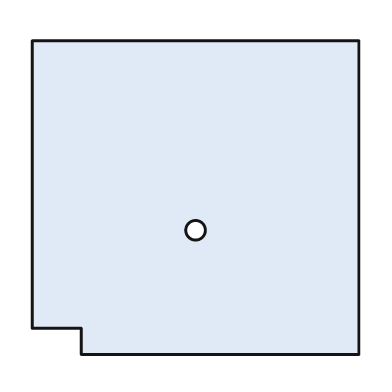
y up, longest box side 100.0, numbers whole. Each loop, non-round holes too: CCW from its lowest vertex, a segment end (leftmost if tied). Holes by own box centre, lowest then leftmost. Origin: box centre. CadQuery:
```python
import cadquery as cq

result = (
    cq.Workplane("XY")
    .moveTo(-35.0, -48.0)
    .lineTo(50.0, -48.0)
    .lineTo(50.0, 48.0)
    .lineTo(-50.0, 48.0)
    .lineTo(-50.0, -40.0)
    .lineTo(-35.0, -40.0)
    .close()
    .moveTo(0.0, -10.0)
    .circle(3.0)
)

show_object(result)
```